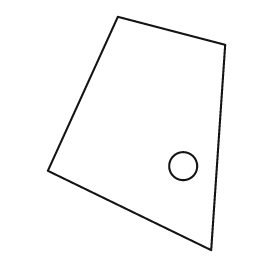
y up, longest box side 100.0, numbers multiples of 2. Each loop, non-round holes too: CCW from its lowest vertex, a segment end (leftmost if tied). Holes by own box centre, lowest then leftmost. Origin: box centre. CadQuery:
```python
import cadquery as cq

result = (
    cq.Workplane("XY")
    .moveTo(32.0, -50.0)
    .lineTo(38.0, 38.0)
    .lineTo(-8.0, 50.0)
    .lineTo(-38.0, -16.0)
    .close()
    .moveTo(20.0, -14.0)
    .circle(6.0)
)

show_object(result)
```